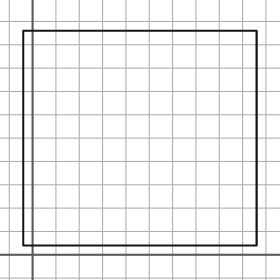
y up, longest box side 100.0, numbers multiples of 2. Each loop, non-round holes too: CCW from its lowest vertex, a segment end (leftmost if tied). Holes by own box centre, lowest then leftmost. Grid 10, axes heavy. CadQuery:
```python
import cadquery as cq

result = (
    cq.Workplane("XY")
    .moveTo(-4.0, 4.0)
    .lineTo(96.0, 4.0)
    .lineTo(96.0, 96.0)
    .lineTo(-4.0, 96.0)
    .close()
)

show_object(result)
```